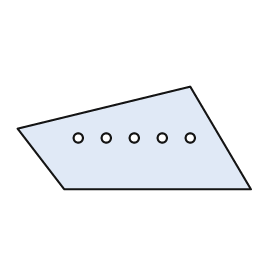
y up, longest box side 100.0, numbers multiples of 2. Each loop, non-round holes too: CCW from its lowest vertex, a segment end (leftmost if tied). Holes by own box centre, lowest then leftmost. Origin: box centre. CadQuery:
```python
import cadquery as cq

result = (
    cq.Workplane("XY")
    .moveTo(-30.0, -22.0)
    .lineTo(50.0, -22.0)
    .lineTo(24.0, 22.0)
    .lineTo(-50.0, 4.0)
    .close()
    .moveTo(-24.0, 0.0)
    .circle(2.0)
    .moveTo(-12.0, 0.0)
    .circle(2.0)
    .moveTo(0.0, 0.0)
    .circle(2.0)
    .moveTo(12.0, 0.0)
    .circle(2.0)
    .moveTo(24.0, 0.0)
    .circle(2.0)
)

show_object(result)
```